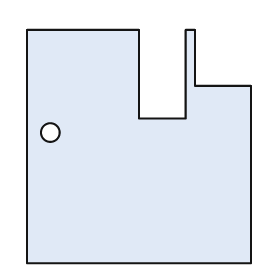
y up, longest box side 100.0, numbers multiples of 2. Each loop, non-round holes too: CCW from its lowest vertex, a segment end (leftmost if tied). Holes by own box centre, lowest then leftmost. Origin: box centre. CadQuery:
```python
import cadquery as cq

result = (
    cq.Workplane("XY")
    .moveTo(-48.0, -50.0)
    .lineTo(48.0, -50.0)
    .lineTo(48.0, 26.0)
    .lineTo(24.0, 26.0)
    .lineTo(24.0, 50.0)
    .lineTo(20.0, 50.0)
    .lineTo(20.0, 12.0)
    .lineTo(0.0, 12.0)
    .lineTo(0.0, 50.0)
    .lineTo(-48.0, 50.0)
    .close()
    .moveTo(-38.0, 6.0)
    .circle(4.0)
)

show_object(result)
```